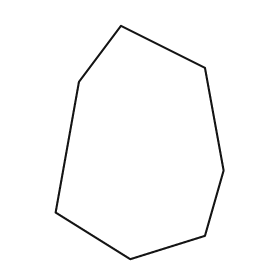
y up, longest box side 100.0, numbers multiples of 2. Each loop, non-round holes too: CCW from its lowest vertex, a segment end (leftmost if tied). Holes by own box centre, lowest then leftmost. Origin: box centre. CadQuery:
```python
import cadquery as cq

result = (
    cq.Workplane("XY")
    .moveTo(-4.0, -50.0)
    .lineTo(28.0, -40.0)
    .lineTo(36.0, -12.0)
    .lineTo(28.0, 32.0)
    .lineTo(-8.0, 50.0)
    .lineTo(-26.0, 26.0)
    .lineTo(-36.0, -30.0)
    .close()
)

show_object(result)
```